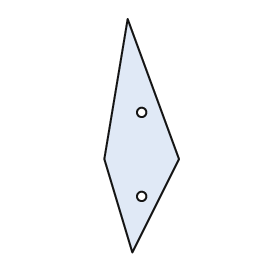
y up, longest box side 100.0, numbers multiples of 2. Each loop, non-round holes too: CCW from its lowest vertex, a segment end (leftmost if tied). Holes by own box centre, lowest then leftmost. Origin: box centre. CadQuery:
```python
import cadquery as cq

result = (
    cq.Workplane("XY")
    .moveTo(-4.0, -50.0)
    .lineTo(16.0, -10.0)
    .lineTo(-6.0, 50.0)
    .lineTo(-16.0, -10.0)
    .close()
    .moveTo(0.0, -26.0)
    .circle(2.0)
    .moveTo(0.0, 10.0)
    .circle(2.0)
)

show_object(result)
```